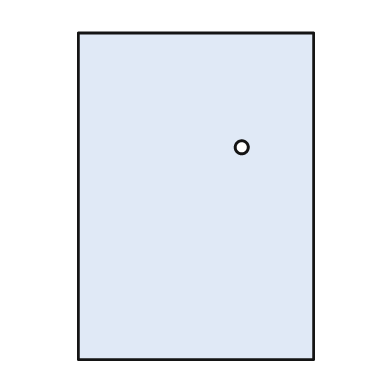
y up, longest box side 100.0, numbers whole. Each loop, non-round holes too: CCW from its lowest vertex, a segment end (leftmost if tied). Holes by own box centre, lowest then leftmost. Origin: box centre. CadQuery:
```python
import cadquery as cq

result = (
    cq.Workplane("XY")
    .moveTo(-36.0, -50.0)
    .lineTo(36.0, -50.0)
    .lineTo(36.0, 50.0)
    .lineTo(-36.0, 50.0)
    .close()
    .moveTo(14.0, 15.0)
    .circle(2.0)
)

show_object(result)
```